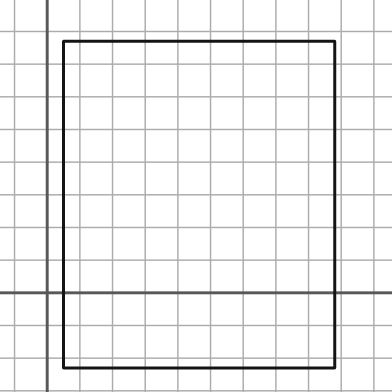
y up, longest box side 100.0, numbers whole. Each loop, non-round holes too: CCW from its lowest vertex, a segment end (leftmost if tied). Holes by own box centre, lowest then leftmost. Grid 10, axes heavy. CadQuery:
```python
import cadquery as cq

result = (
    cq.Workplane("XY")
    .moveTo(5.0, -23.0)
    .lineTo(88.0, -23.0)
    .lineTo(88.0, 77.0)
    .lineTo(5.0, 77.0)
    .close()
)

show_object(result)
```